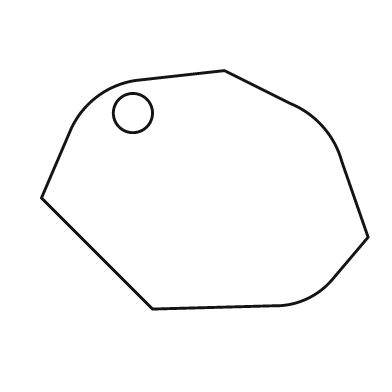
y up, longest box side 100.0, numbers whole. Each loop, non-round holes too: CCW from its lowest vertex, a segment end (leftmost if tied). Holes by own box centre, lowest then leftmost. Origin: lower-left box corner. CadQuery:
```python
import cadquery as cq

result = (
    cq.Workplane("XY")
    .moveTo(34.0, 0.0)
    .lineTo(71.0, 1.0)
    .threePointArc((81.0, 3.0), (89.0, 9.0))
    .lineTo(100.0, 22.0)
    .lineTo(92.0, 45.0)
    .threePointArc((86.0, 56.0), (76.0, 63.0))
    .lineTo(56.0, 73.0)
    .lineTo(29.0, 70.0)
    .threePointArc((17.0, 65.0), (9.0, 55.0))
    .lineTo(0.0, 34.0)
    .close()
    .moveTo(28.0, 60.0)
    .circle(6.0)
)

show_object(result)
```